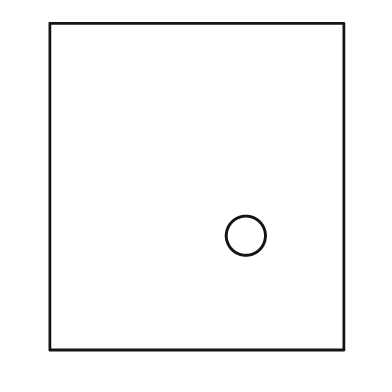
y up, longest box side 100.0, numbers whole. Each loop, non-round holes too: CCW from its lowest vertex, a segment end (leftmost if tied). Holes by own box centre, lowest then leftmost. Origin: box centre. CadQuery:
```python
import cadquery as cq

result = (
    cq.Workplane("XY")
    .moveTo(-45.0, -50.0)
    .lineTo(45.0, -50.0)
    .lineTo(45.0, 50.0)
    .lineTo(-45.0, 50.0)
    .close()
    .moveTo(15.0, -15.0)
    .circle(6.0)
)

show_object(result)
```